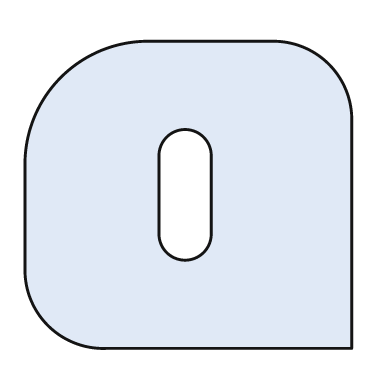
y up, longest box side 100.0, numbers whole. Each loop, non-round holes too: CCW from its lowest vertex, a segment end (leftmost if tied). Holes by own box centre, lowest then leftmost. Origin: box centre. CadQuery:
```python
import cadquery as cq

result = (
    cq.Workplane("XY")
    .moveTo(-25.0, -47.0)
    .lineTo(50.0, -47.0)
    .lineTo(50.0, 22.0)
    .threePointArc((43.0, 40.0), (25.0, 47.0))
    .lineTo(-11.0, 47.0)
    .threePointArc((-39.0, 36.0), (-50.0, 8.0))
    .lineTo(-50.0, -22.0)
    .threePointArc((-43.0, -40.0), (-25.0, -47.0))
    .close()
    .moveTo(-9.0, -12.0)
    .threePointArc((-1.0, -20.0), (7.0, -12.0))
    .lineTo(7.0, 12.0)
    .threePointArc((-1.0, 20.0), (-9.0, 12.0))
    .close()
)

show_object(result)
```